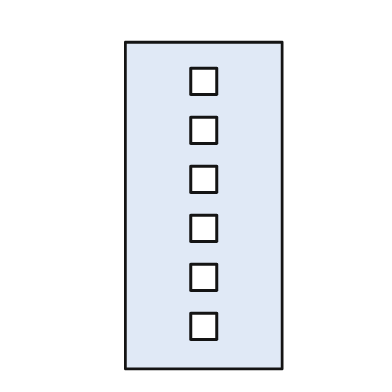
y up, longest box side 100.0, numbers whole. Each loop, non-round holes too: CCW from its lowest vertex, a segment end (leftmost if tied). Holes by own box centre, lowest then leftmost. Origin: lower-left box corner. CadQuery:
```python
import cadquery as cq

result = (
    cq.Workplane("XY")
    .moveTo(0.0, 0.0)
    .lineTo(48.0, 0.0)
    .lineTo(48.0, 100.0)
    .lineTo(0.0, 100.0)
    .close()
    .moveTo(20.0, 9.0)
    .lineTo(28.0, 9.0)
    .lineTo(28.0, 17.0)
    .lineTo(20.0, 17.0)
    .close()
    .moveTo(20.0, 24.0)
    .lineTo(28.0, 24.0)
    .lineTo(28.0, 32.0)
    .lineTo(20.0, 32.0)
    .close()
    .moveTo(20.0, 39.0)
    .lineTo(28.0, 39.0)
    .lineTo(28.0, 47.0)
    .lineTo(20.0, 47.0)
    .close()
    .moveTo(20.0, 54.0)
    .lineTo(28.0, 54.0)
    .lineTo(28.0, 62.0)
    .lineTo(20.0, 62.0)
    .close()
    .moveTo(20.0, 69.0)
    .lineTo(28.0, 69.0)
    .lineTo(28.0, 77.0)
    .lineTo(20.0, 77.0)
    .close()
    .moveTo(20.0, 84.0)
    .lineTo(28.0, 84.0)
    .lineTo(28.0, 92.0)
    .lineTo(20.0, 92.0)
    .close()
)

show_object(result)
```